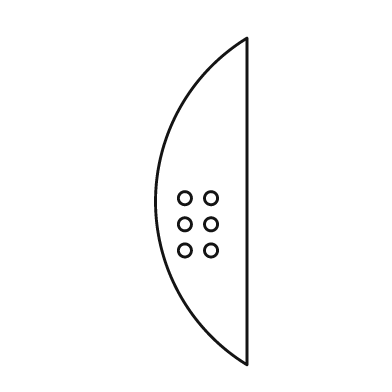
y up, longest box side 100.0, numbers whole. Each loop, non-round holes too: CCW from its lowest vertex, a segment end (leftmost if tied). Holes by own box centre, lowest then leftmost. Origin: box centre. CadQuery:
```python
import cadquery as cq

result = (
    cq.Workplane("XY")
    .moveTo(14.0, -50.0)
    .lineTo(14.0, 50.0)
    .threePointArc((-14.0, 0.0), (14.0, -50.0))
    .close()
    .moveTo(-5.0, -15.0)
    .circle(2.0)
    .moveTo(3.0, -15.0)
    .circle(2.0)
    .moveTo(-5.0, -7.0)
    .circle(2.0)
    .moveTo(3.0, -7.0)
    .circle(2.0)
    .moveTo(-5.0, 1.0)
    .circle(2.0)
    .moveTo(3.0, 1.0)
    .circle(2.0)
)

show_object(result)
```